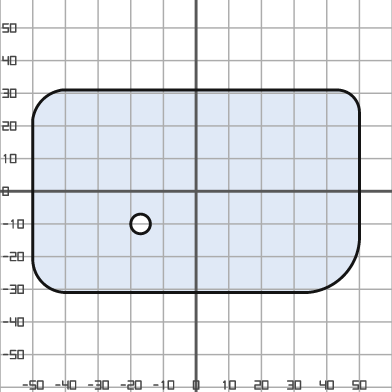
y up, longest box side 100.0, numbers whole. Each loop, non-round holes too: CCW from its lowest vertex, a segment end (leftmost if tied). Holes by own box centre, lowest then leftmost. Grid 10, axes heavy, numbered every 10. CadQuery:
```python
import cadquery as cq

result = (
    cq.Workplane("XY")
    .moveTo(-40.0, -31.0)
    .lineTo(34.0, -31.0)
    .threePointArc((45.0, -26.0), (50.0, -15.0))
    .lineTo(50.0, 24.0)
    .threePointArc((48.0, 29.0), (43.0, 31.0))
    .lineTo(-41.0, 31.0)
    .threePointArc((-47.0, 28.0), (-50.0, 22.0))
    .lineTo(-50.0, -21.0)
    .threePointArc((-47.0, -28.0), (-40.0, -31.0))
    .close()
    .moveTo(-17.0, -10.0)
    .circle(3.0)
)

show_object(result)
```